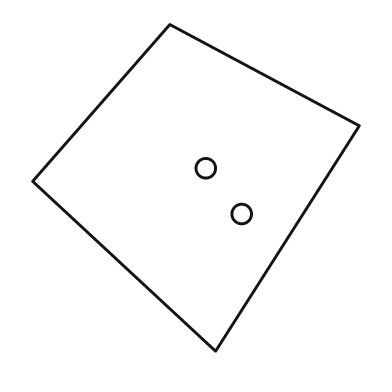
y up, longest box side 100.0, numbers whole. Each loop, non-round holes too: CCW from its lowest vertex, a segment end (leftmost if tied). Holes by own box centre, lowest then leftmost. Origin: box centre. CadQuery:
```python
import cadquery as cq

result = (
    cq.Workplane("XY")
    .moveTo(6.0, -50.0)
    .lineTo(50.0, 19.0)
    .lineTo(-8.0, 50.0)
    .lineTo(-50.0, 2.0)
    .close()
    .moveTo(14.0, -8.0)
    .circle(3.0)
    .moveTo(3.0, 6.0)
    .circle(3.0)
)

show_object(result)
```